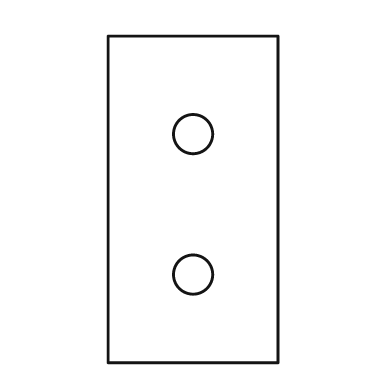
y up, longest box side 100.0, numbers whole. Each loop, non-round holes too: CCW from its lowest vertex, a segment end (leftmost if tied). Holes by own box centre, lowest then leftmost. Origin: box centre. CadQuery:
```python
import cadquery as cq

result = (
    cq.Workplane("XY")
    .moveTo(-26.0, -50.0)
    .lineTo(26.0, -50.0)
    .lineTo(26.0, 50.0)
    .lineTo(-26.0, 50.0)
    .close()
    .moveTo(0.0, -23.0)
    .circle(6.0)
    .moveTo(0.0, 20.0)
    .circle(6.0)
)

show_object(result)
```